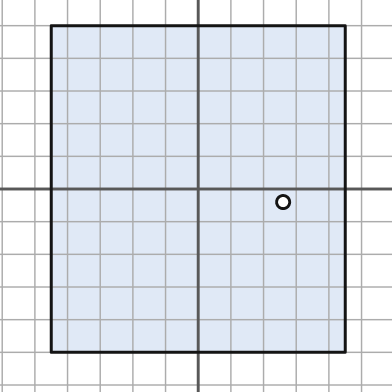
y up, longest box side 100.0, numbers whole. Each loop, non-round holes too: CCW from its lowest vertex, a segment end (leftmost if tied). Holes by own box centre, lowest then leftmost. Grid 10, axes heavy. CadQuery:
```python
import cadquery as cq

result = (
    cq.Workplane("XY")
    .moveTo(-45.0, -50.0)
    .lineTo(45.0, -50.0)
    .lineTo(45.0, 50.0)
    .lineTo(-45.0, 50.0)
    .close()
    .moveTo(26.0, -4.0)
    .circle(2.0)
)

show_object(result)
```